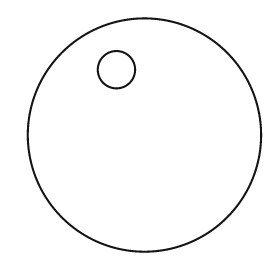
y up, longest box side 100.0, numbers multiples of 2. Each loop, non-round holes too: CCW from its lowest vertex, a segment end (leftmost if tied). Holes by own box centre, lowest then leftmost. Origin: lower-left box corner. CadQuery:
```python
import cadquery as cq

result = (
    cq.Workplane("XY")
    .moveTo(50.0, 50.0)
    .circle(50.0)
    .moveTo(38.0, 78.0)
    .circle(8.0)
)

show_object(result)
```